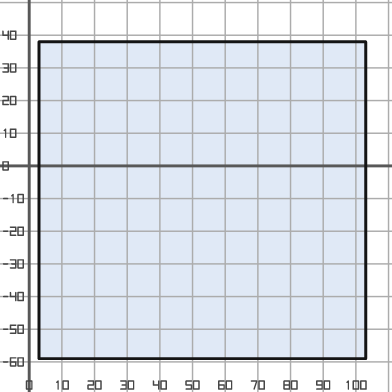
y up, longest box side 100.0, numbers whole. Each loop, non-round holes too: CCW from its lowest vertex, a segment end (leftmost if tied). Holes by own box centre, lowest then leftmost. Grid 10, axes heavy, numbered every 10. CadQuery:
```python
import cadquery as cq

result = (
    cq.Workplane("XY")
    .moveTo(3.0, -59.0)
    .lineTo(103.0, -59.0)
    .lineTo(103.0, 38.0)
    .lineTo(3.0, 38.0)
    .close()
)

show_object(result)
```